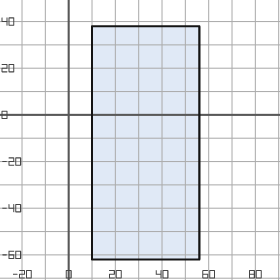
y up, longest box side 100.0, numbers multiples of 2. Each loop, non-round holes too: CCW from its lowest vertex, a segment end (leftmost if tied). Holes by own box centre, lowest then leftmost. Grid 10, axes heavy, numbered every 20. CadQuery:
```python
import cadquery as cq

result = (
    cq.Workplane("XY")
    .moveTo(10.0, -62.0)
    .lineTo(56.0, -62.0)
    .lineTo(56.0, 38.0)
    .lineTo(10.0, 38.0)
    .close()
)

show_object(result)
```